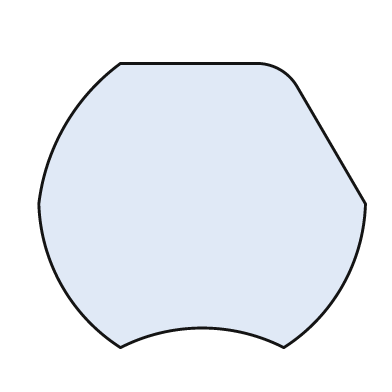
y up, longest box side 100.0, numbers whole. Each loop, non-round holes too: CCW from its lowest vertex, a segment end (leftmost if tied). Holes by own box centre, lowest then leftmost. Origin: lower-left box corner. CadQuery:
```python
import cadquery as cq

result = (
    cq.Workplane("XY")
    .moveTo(25.0, 0.0)
    .threePointArc((50.0, 6.0), (75.0, 0.0))
    .threePointArc((93.0, 19.0), (100.0, 44.0))
    .lineTo(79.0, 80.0)
    .threePointArc((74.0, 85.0), (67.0, 87.0))
    .lineTo(25.0, 87.0)
    .threePointArc((8.0, 68.0), (0.0, 44.0))
    .threePointArc((7.0, 19.0), (25.0, 0.0))
    .close()
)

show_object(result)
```